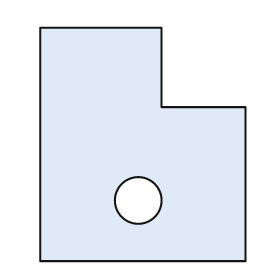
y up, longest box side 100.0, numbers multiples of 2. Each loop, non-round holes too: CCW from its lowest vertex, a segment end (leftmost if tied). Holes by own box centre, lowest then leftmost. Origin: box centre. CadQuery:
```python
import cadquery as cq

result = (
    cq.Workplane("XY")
    .moveTo(-44.0, -50.0)
    .lineTo(44.0, -50.0)
    .lineTo(44.0, 16.0)
    .lineTo(8.0, 16.0)
    .lineTo(8.0, 50.0)
    .lineTo(-44.0, 50.0)
    .close()
    .moveTo(-2.0, -24.0)
    .circle(10.0)
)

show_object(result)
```